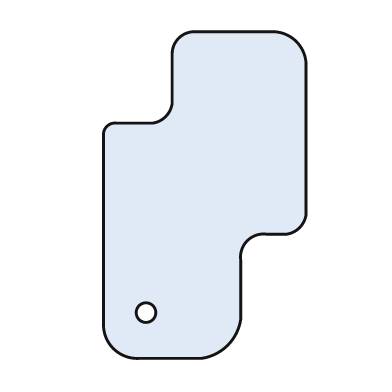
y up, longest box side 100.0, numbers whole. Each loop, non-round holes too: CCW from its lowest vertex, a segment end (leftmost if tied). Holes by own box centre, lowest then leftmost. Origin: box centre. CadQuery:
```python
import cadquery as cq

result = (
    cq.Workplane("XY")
    .moveTo(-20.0, -50.0)
    .lineTo(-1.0, -50.0)
    .threePointArc((7.0, -46.0), (11.0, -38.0))
    .lineTo(11.0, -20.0)
    .threePointArc((13.0, -14.0), (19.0, -12.0))
    .lineTo(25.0, -12.0)
    .threePointArc((29.0, -10.0), (31.0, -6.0))
    .lineTo(31.0, 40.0)
    .threePointArc((28.0, 47.0), (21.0, 50.0))
    .lineTo(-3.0, 50.0)
    .threePointArc((-8.0, 48.0), (-10.0, 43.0))
    .lineTo(-10.0, 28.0)
    .threePointArc((-12.0, 24.0), (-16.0, 22.0))
    .lineTo(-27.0, 22.0)
    .threePointArc((-30.0, 21.0), (-31.0, 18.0))
    .lineTo(-31.0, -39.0)
    .threePointArc((-28.0, -47.0), (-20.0, -50.0))
    .close()
    .moveTo(-18.0, -36.0)
    .circle(3.0)
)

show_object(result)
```